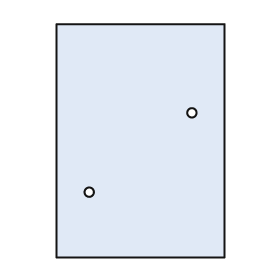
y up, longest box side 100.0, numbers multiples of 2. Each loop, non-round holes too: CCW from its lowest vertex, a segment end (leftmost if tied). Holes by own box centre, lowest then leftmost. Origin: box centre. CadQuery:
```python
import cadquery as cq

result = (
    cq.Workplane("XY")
    .moveTo(-36.0, -50.0)
    .lineTo(36.0, -50.0)
    .lineTo(36.0, 50.0)
    .lineTo(-36.0, 50.0)
    .close()
    .moveTo(-22.0, -22.0)
    .circle(2.0)
    .moveTo(22.0, 12.0)
    .circle(2.0)
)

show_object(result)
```